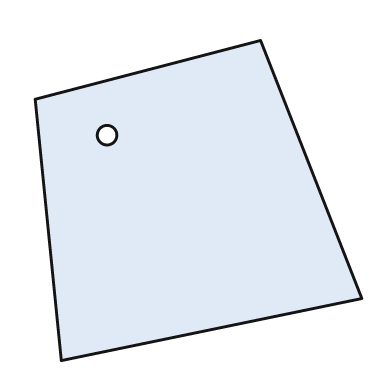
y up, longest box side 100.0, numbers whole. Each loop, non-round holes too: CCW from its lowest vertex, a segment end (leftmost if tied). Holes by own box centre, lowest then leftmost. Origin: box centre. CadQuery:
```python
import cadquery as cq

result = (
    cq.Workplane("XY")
    .moveTo(-42.0, -49.0)
    .lineTo(50.0, -30.0)
    .lineTo(19.0, 49.0)
    .lineTo(-50.0, 31.0)
    .close()
    .moveTo(-28.0, 20.0)
    .circle(3.0)
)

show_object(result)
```